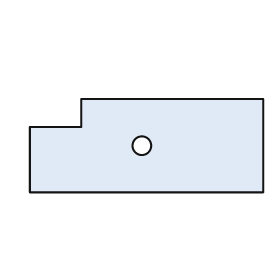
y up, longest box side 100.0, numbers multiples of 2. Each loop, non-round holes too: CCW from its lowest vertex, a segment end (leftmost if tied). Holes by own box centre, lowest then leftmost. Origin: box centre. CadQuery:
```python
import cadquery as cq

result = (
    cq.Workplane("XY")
    .moveTo(-50.0, -20.0)
    .lineTo(50.0, -20.0)
    .lineTo(50.0, 20.0)
    .lineTo(-28.0, 20.0)
    .lineTo(-28.0, 8.0)
    .lineTo(-50.0, 8.0)
    .close()
    .moveTo(-2.0, 0.0)
    .circle(4.0)
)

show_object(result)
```